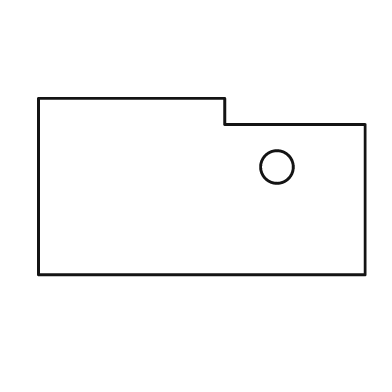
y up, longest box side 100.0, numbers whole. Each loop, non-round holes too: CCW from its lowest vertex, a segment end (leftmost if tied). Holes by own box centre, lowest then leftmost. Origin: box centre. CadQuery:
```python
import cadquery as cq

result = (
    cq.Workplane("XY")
    .moveTo(-50.0, -27.0)
    .lineTo(50.0, -27.0)
    .lineTo(50.0, 19.0)
    .lineTo(7.0, 19.0)
    .lineTo(7.0, 27.0)
    .lineTo(-50.0, 27.0)
    .close()
    .moveTo(23.0, 6.0)
    .circle(5.0)
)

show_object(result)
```